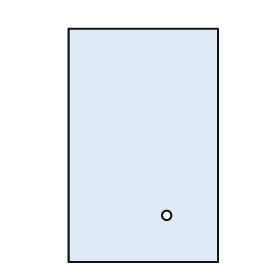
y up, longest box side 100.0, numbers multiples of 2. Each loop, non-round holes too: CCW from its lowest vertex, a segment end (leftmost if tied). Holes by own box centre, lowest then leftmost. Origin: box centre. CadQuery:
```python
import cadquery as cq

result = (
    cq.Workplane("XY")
    .moveTo(-32.0, -50.0)
    .lineTo(32.0, -50.0)
    .lineTo(32.0, 50.0)
    .lineTo(-32.0, 50.0)
    .close()
    .moveTo(10.0, -30.0)
    .circle(2.0)
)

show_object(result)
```